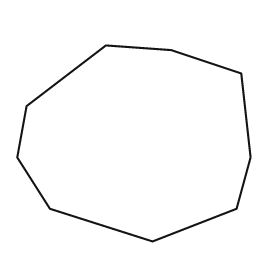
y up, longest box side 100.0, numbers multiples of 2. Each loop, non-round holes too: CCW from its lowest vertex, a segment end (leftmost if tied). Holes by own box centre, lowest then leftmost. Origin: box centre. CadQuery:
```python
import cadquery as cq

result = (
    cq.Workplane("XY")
    .moveTo(8.0, -42.0)
    .lineTo(44.0, -28.0)
    .lineTo(50.0, -6.0)
    .lineTo(46.0, 30.0)
    .lineTo(16.0, 40.0)
    .lineTo(-12.0, 42.0)
    .lineTo(-46.0, 16.0)
    .lineTo(-50.0, -6.0)
    .lineTo(-36.0, -28.0)
    .close()
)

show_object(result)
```